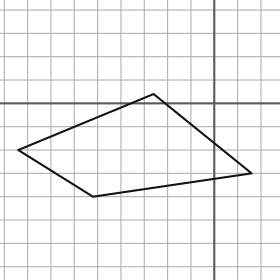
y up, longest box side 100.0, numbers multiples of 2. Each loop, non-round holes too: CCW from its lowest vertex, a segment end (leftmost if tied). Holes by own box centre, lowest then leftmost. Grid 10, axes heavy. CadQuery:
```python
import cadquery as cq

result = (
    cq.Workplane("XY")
    .moveTo(-52.0, -40.0)
    .lineTo(16.0, -30.0)
    .lineTo(-26.0, 4.0)
    .lineTo(-84.0, -20.0)
    .close()
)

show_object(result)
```